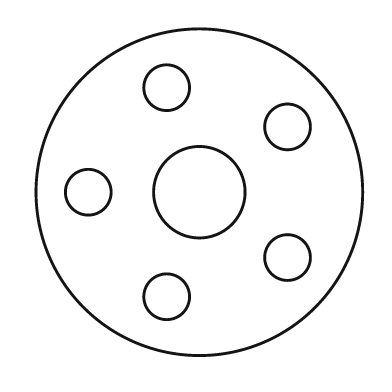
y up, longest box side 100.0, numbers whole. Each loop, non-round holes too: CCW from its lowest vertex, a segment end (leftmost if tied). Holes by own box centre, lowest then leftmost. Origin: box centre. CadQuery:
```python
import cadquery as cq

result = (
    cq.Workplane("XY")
    .moveTo(0.0, 0.0)
    .circle(50.0)
    .moveTo(-10.0, -32.0)
    .circle(7.0)
    .moveTo(27.0, -20.0)
    .circle(7.0)
    .moveTo(-34.0, 0.0)
    .circle(7.0)
    .moveTo(0.0, 0.0)
    .circle(14.0)
    .moveTo(27.0, 20.0)
    .circle(7.0)
    .moveTo(-10.0, 32.0)
    .circle(7.0)
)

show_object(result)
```